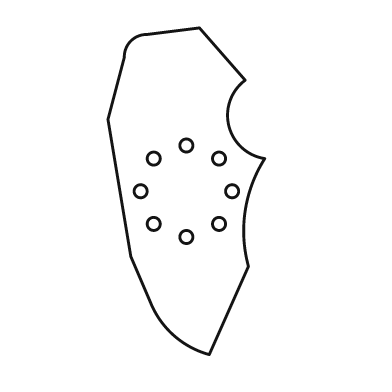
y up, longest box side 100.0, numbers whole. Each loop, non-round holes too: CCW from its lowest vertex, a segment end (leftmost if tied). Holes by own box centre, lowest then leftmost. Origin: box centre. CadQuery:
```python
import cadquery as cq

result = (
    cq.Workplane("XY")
    .moveTo(7.0, -50.0)
    .lineTo(19.0, -23.0)
    .threePointArc((18.0, -6.0), (24.0, 10.0))
    .threePointArc((13.0, 20.0), (18.0, 34.0))
    .lineTo(4.0, 50.0)
    .lineTo(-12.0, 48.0)
    .threePointArc((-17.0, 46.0), (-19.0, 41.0))
    .lineTo(-24.0, 22.0)
    .lineTo(-17.0, -20.0)
    .lineTo(-11.0, -34.0)
    .threePointArc((-4.0, -44.0), (7.0, -50.0))
    .close()
    .moveTo(0.0, -14.0)
    .circle(2.0)
    .moveTo(-10.0, -10.0)
    .circle(2.0)
    .moveTo(10.0, -10.0)
    .circle(2.0)
    .moveTo(-14.0, 0.0)
    .circle(2.0)
    .moveTo(14.0, 0.0)
    .circle(2.0)
    .moveTo(-10.0, 10.0)
    .circle(2.0)
    .moveTo(10.0, 10.0)
    .circle(2.0)
    .moveTo(0.0, 14.0)
    .circle(2.0)
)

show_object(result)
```